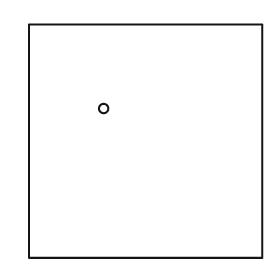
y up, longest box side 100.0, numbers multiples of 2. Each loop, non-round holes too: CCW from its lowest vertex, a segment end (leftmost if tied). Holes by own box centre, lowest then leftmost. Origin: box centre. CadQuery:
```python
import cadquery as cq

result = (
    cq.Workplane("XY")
    .moveTo(-50.0, -50.0)
    .lineTo(50.0, -50.0)
    .lineTo(50.0, 50.0)
    .lineTo(-50.0, 50.0)
    .close()
    .moveTo(-18.0, 14.0)
    .circle(2.0)
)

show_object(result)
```